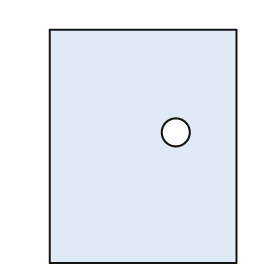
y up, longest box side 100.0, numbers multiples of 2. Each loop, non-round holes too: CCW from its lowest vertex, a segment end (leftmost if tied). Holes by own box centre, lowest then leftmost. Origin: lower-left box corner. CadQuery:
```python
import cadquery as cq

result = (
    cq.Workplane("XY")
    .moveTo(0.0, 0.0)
    .lineTo(80.0, 0.0)
    .lineTo(80.0, 100.0)
    .lineTo(0.0, 100.0)
    .close()
    .moveTo(54.0, 56.0)
    .circle(6.0)
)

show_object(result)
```